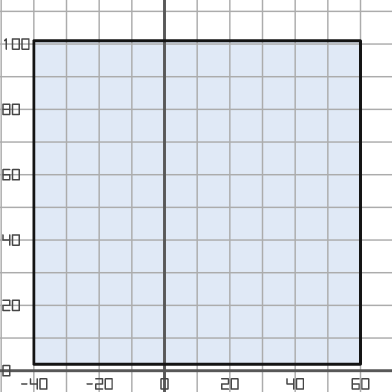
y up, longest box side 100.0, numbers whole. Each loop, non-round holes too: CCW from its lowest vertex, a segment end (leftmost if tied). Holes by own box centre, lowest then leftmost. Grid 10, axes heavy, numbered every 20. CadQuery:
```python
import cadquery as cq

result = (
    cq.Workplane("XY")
    .moveTo(-40.0, 2.0)
    .lineTo(60.0, 2.0)
    .lineTo(60.0, 101.0)
    .lineTo(-40.0, 101.0)
    .close()
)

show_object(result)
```